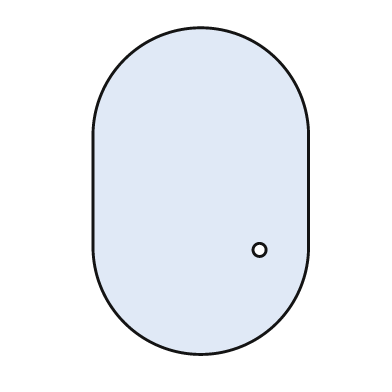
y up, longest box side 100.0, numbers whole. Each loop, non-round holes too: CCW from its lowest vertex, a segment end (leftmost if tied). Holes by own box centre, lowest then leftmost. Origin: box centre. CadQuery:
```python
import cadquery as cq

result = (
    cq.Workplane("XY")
    .moveTo(-33.0, -17.0)
    .threePointArc((0.0, -50.0), (33.0, -17.0))
    .lineTo(33.0, 17.0)
    .threePointArc((0.0, 50.0), (-33.0, 17.0))
    .close()
    .moveTo(18.0, -18.0)
    .circle(2.0)
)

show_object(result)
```